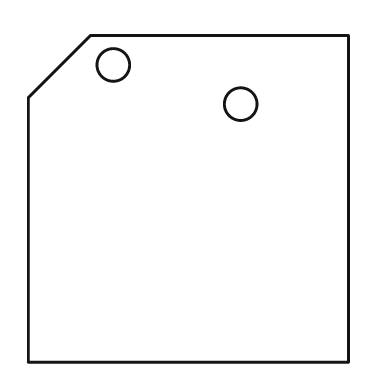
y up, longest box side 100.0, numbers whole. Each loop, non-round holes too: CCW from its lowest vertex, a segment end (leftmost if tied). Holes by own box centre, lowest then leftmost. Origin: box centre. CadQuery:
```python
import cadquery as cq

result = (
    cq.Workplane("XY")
    .moveTo(-49.0, -50.0)
    .lineTo(49.0, -50.0)
    .lineTo(49.0, 50.0)
    .lineTo(-30.0, 50.0)
    .lineTo(-49.0, 31.0)
    .close()
    .moveTo(16.0, 29.0)
    .circle(5.0)
    .moveTo(-23.0, 41.0)
    .circle(5.0)
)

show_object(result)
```